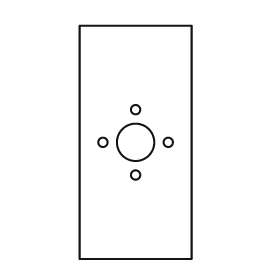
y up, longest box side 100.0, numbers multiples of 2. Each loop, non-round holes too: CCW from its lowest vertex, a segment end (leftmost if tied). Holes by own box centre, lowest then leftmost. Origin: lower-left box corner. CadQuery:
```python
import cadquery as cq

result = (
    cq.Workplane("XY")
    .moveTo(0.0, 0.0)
    .lineTo(48.0, 0.0)
    .lineTo(48.0, 100.0)
    .lineTo(0.0, 100.0)
    .close()
    .moveTo(24.0, 36.0)
    .circle(2.0)
    .moveTo(10.0, 50.0)
    .circle(2.0)
    .moveTo(24.0, 50.0)
    .circle(8.0)
    .moveTo(38.0, 50.0)
    .circle(2.0)
    .moveTo(24.0, 64.0)
    .circle(2.0)
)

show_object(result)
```